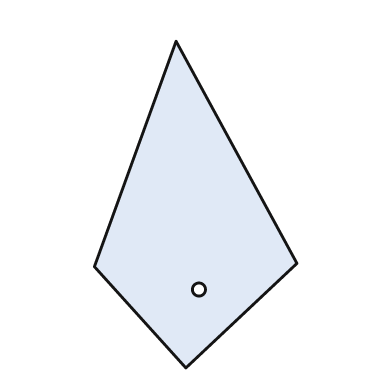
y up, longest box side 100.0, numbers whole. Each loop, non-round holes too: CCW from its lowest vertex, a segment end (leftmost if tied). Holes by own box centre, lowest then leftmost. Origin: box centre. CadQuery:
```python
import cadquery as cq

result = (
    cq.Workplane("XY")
    .moveTo(-3.0, -50.0)
    .lineTo(31.0, -18.0)
    .lineTo(-6.0, 50.0)
    .lineTo(-31.0, -19.0)
    .close()
    .moveTo(1.0, -26.0)
    .circle(2.0)
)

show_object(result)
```